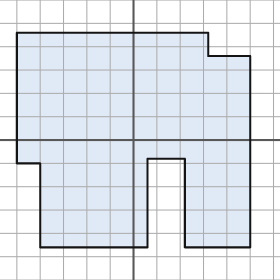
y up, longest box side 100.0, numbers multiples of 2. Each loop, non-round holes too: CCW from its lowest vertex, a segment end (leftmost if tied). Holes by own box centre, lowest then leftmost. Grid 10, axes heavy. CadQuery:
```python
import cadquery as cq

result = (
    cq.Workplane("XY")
    .moveTo(-40.0, -46.0)
    .lineTo(6.0, -46.0)
    .lineTo(6.0, -8.0)
    .lineTo(22.0, -8.0)
    .lineTo(22.0, -46.0)
    .lineTo(50.0, -46.0)
    .lineTo(50.0, 36.0)
    .lineTo(32.0, 36.0)
    .lineTo(32.0, 46.0)
    .lineTo(-50.0, 46.0)
    .lineTo(-50.0, -10.0)
    .lineTo(-40.0, -10.0)
    .close()
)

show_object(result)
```